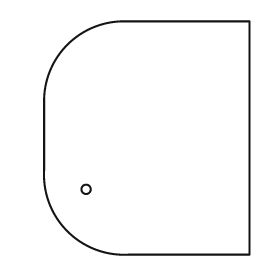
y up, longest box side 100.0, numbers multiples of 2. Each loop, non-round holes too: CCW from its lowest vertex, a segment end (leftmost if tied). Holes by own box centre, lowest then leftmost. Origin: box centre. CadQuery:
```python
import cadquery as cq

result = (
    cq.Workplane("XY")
    .moveTo(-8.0, -50.0)
    .lineTo(44.0, -50.0)
    .lineTo(44.0, 50.0)
    .lineTo(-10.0, 50.0)
    .threePointArc((-34.0, 40.0), (-44.0, 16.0))
    .lineTo(-44.0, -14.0)
    .threePointArc((-34.0, -40.0), (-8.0, -50.0))
    .close()
    .moveTo(-26.0, -22.0)
    .circle(2.0)
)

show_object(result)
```